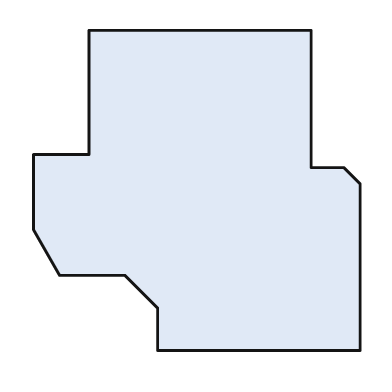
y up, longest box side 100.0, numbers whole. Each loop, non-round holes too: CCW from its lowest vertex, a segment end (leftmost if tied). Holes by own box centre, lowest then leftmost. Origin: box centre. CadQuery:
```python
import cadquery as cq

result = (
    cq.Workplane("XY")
    .moveTo(-12.0, -49.0)
    .lineTo(50.0, -49.0)
    .lineTo(50.0, 2.0)
    .lineTo(45.0, 7.0)
    .lineTo(35.0, 7.0)
    .lineTo(35.0, 49.0)
    .lineTo(-33.0, 49.0)
    .lineTo(-33.0, 11.0)
    .lineTo(-50.0, 11.0)
    .lineTo(-50.0, -12.0)
    .lineTo(-42.0, -26.0)
    .lineTo(-22.0, -26.0)
    .lineTo(-12.0, -36.0)
    .close()
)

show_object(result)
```